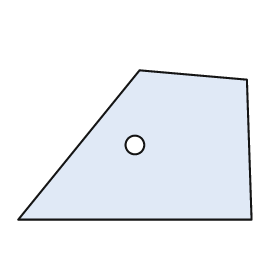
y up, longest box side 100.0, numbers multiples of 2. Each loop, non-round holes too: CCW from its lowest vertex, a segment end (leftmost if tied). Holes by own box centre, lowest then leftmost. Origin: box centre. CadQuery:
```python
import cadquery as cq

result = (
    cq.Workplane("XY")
    .moveTo(-50.0, -32.0)
    .lineTo(50.0, -32.0)
    .lineTo(48.0, 28.0)
    .lineTo(2.0, 32.0)
    .close()
    .moveTo(0.0, 0.0)
    .circle(4.0)
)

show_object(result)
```